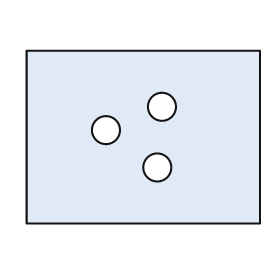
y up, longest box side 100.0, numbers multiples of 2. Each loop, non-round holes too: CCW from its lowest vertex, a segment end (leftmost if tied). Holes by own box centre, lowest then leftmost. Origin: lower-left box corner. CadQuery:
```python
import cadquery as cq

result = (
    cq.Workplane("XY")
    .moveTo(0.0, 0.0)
    .lineTo(100.0, 0.0)
    .lineTo(100.0, 74.0)
    .lineTo(0.0, 74.0)
    .close()
    .moveTo(56.0, 24.0)
    .circle(6.0)
    .moveTo(34.0, 40.0)
    .circle(6.0)
    .moveTo(58.0, 50.0)
    .circle(6.0)
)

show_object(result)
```